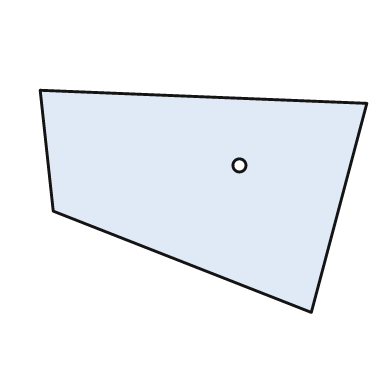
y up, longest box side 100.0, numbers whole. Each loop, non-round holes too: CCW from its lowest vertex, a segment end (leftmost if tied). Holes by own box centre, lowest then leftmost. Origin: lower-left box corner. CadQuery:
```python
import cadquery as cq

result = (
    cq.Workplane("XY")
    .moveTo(83.0, 0.0)
    .lineTo(100.0, 64.0)
    .lineTo(0.0, 68.0)
    .lineTo(4.0, 31.0)
    .close()
    .moveTo(61.0, 45.0)
    .circle(2.0)
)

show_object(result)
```